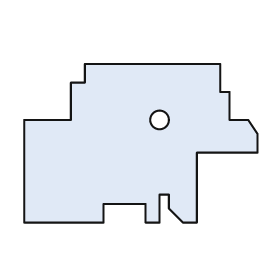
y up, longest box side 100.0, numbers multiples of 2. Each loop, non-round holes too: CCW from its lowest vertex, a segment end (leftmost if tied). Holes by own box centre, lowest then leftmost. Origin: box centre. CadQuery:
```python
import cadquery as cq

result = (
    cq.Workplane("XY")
    .moveTo(-50.0, -34.0)
    .lineTo(-16.0, -34.0)
    .lineTo(-16.0, -26.0)
    .lineTo(2.0, -26.0)
    .lineTo(2.0, -34.0)
    .lineTo(8.0, -34.0)
    .lineTo(8.0, -22.0)
    .lineTo(12.0, -22.0)
    .lineTo(12.0, -28.0)
    .lineTo(18.0, -34.0)
    .lineTo(24.0, -34.0)
    .lineTo(24.0, -4.0)
    .lineTo(50.0, -4.0)
    .lineTo(50.0, 4.0)
    .lineTo(46.0, 10.0)
    .lineTo(38.0, 10.0)
    .lineTo(38.0, 22.0)
    .lineTo(34.0, 22.0)
    .lineTo(34.0, 34.0)
    .lineTo(-24.0, 34.0)
    .lineTo(-24.0, 26.0)
    .lineTo(-30.0, 26.0)
    .lineTo(-30.0, 10.0)
    .lineTo(-50.0, 10.0)
    .close()
    .moveTo(8.0, 10.0)
    .circle(4.0)
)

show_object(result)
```